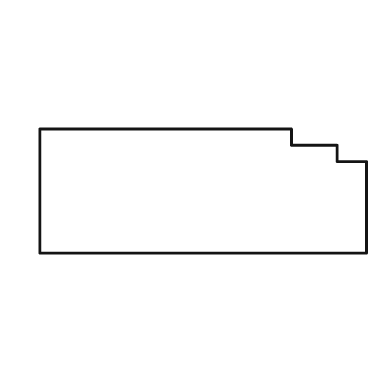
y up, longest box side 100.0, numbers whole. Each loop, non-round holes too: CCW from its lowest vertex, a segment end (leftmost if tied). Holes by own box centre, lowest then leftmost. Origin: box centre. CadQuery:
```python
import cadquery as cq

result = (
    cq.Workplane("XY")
    .moveTo(-50.0, -19.0)
    .lineTo(50.0, -19.0)
    .lineTo(50.0, 9.0)
    .lineTo(41.0, 9.0)
    .lineTo(41.0, 14.0)
    .lineTo(27.0, 14.0)
    .lineTo(27.0, 19.0)
    .lineTo(-50.0, 19.0)
    .close()
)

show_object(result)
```